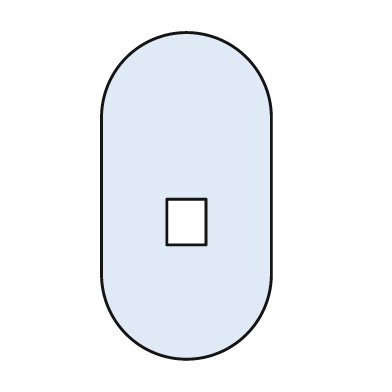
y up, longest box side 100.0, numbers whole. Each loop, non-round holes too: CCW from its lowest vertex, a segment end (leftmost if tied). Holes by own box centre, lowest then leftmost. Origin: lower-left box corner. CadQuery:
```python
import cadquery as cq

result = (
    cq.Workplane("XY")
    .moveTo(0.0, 26.0)
    .threePointArc((26.0, 0.0), (52.0, 26.0))
    .lineTo(52.0, 74.0)
    .threePointArc((26.0, 100.0), (0.0, 74.0))
    .close()
    .moveTo(20.0, 35.0)
    .lineTo(32.0, 35.0)
    .lineTo(32.0, 49.0)
    .lineTo(20.0, 49.0)
    .close()
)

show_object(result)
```